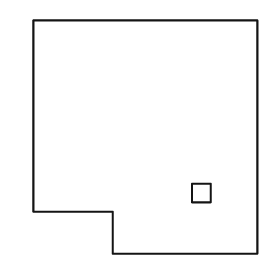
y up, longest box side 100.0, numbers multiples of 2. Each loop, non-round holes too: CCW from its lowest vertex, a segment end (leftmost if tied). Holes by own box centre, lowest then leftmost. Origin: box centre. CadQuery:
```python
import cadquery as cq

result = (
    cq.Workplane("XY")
    .moveTo(-14.0, -50.0)
    .lineTo(48.0, -50.0)
    .lineTo(48.0, 50.0)
    .lineTo(-48.0, 50.0)
    .lineTo(-48.0, -32.0)
    .lineTo(-14.0, -32.0)
    .close()
    .moveTo(20.0, -28.0)
    .lineTo(28.0, -28.0)
    .lineTo(28.0, -20.0)
    .lineTo(20.0, -20.0)
    .close()
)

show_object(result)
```